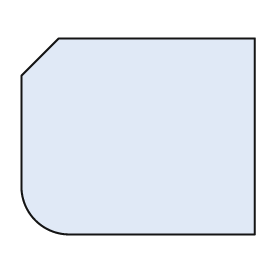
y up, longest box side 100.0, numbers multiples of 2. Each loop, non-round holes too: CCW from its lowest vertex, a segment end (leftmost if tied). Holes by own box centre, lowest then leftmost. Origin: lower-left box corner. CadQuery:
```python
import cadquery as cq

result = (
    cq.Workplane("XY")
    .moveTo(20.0, 0.0)
    .lineTo(100.0, 0.0)
    .lineTo(100.0, 84.0)
    .lineTo(16.0, 84.0)
    .lineTo(0.0, 68.0)
    .lineTo(0.0, 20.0)
    .threePointArc((6.0, 6.0), (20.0, 0.0))
    .close()
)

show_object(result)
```